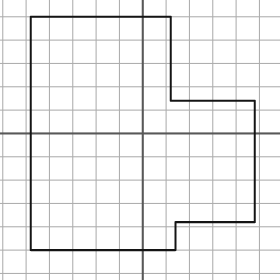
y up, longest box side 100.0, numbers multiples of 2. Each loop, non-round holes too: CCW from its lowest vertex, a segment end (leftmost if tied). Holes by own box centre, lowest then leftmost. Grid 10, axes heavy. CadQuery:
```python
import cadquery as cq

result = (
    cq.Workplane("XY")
    .moveTo(-48.0, -50.0)
    .lineTo(14.0, -50.0)
    .lineTo(14.0, -38.0)
    .lineTo(48.0, -38.0)
    .lineTo(48.0, 14.0)
    .lineTo(12.0, 14.0)
    .lineTo(12.0, 50.0)
    .lineTo(-48.0, 50.0)
    .close()
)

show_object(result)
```